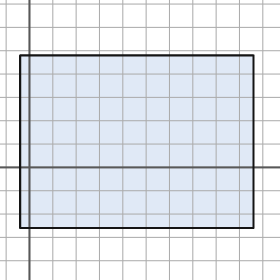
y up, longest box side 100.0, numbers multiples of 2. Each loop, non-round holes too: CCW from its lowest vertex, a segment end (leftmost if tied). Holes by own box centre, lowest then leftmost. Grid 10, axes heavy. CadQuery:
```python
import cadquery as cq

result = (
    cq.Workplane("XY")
    .moveTo(-4.0, -26.0)
    .lineTo(96.0, -26.0)
    .lineTo(96.0, 48.0)
    .lineTo(-4.0, 48.0)
    .close()
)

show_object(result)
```